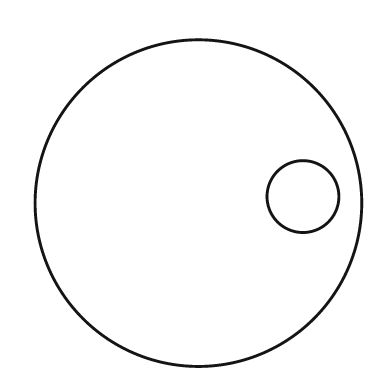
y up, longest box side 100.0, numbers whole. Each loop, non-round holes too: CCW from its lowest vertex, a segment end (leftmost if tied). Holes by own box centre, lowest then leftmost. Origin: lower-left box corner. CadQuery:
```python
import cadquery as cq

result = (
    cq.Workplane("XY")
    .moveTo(50.0, 50.0)
    .circle(50.0)
    .moveTo(82.0, 52.0)
    .circle(11.0)
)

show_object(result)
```